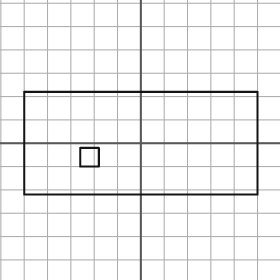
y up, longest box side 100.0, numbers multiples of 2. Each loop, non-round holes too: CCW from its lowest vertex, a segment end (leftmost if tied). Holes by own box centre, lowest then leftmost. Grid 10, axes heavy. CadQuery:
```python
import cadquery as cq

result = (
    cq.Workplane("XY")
    .moveTo(-50.0, -22.0)
    .lineTo(50.0, -22.0)
    .lineTo(50.0, 22.0)
    .lineTo(-50.0, 22.0)
    .close()
    .moveTo(-26.0, -10.0)
    .lineTo(-18.0, -10.0)
    .lineTo(-18.0, -2.0)
    .lineTo(-26.0, -2.0)
    .close()
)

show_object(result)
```